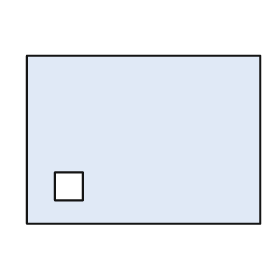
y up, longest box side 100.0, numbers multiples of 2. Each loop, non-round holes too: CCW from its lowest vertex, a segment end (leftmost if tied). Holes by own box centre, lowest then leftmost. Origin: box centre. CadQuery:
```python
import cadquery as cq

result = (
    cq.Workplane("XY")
    .moveTo(-50.0, -36.0)
    .lineTo(50.0, -36.0)
    .lineTo(50.0, 36.0)
    .lineTo(-50.0, 36.0)
    .close()
    .moveTo(-38.0, -26.0)
    .lineTo(-26.0, -26.0)
    .lineTo(-26.0, -14.0)
    .lineTo(-38.0, -14.0)
    .close()
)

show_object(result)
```